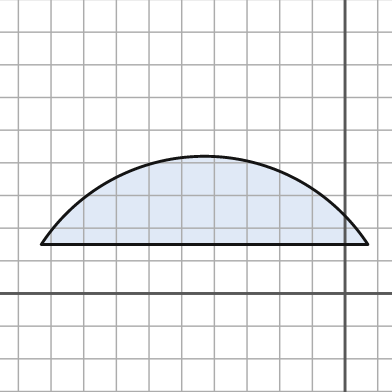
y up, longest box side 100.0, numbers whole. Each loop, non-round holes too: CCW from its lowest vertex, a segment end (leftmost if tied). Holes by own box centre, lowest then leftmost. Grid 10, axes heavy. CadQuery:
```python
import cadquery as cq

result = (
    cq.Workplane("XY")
    .moveTo(-93.0, 15.0)
    .lineTo(7.0, 15.0)
    .threePointArc((-43.0, 42.0), (-93.0, 15.0))
    .close()
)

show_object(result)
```